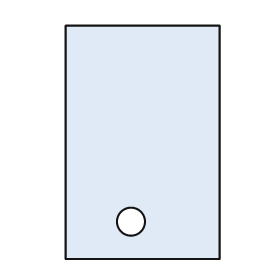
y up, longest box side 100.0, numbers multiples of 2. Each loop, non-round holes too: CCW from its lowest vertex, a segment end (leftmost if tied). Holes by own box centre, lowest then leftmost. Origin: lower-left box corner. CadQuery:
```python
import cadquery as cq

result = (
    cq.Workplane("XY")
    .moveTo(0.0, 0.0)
    .lineTo(66.0, 0.0)
    .lineTo(66.0, 100.0)
    .lineTo(0.0, 100.0)
    .close()
    .moveTo(28.0, 16.0)
    .circle(6.0)
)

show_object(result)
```